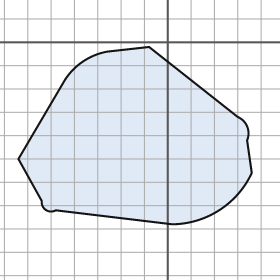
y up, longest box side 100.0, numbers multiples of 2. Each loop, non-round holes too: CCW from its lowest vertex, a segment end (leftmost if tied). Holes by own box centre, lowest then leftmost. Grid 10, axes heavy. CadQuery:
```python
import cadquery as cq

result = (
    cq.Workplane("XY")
    .moveTo(2.0, -78.0)
    .threePointArc((22.0, -72.0), (36.0, -56.0))
    .lineTo(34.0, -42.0)
    .threePointArc((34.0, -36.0), (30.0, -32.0))
    .lineTo(-8.0, -2.0)
    .lineTo(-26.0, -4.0)
    .threePointArc((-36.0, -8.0), (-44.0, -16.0))
    .lineTo(-64.0, -50.0)
    .lineTo(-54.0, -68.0)
    .threePointArc((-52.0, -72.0), (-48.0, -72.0))
    .close()
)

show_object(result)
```